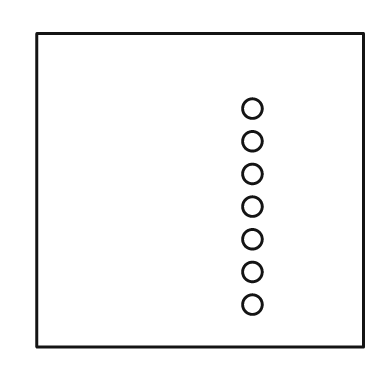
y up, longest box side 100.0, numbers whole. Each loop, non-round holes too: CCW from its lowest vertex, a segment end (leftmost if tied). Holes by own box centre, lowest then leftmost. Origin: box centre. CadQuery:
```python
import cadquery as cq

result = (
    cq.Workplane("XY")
    .moveTo(-50.0, -48.0)
    .lineTo(50.0, -48.0)
    .lineTo(50.0, 48.0)
    .lineTo(-50.0, 48.0)
    .close()
    .moveTo(16.0, -35.0)
    .circle(3.0)
    .moveTo(16.0, -25.0)
    .circle(3.0)
    .moveTo(16.0, -15.0)
    .circle(3.0)
    .moveTo(16.0, -5.0)
    .circle(3.0)
    .moveTo(16.0, 5.0)
    .circle(3.0)
    .moveTo(16.0, 15.0)
    .circle(3.0)
    .moveTo(16.0, 25.0)
    .circle(3.0)
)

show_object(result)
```